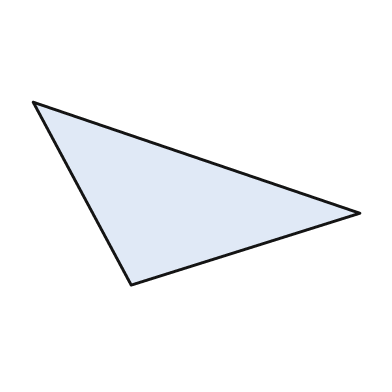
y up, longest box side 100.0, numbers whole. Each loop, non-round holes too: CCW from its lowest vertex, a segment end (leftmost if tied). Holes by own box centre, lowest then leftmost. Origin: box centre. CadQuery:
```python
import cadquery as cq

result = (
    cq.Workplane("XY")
    .moveTo(-20.0, -28.0)
    .lineTo(50.0, -6.0)
    .lineTo(-50.0, 28.0)
    .close()
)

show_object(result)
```